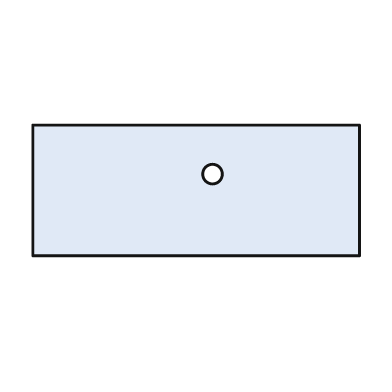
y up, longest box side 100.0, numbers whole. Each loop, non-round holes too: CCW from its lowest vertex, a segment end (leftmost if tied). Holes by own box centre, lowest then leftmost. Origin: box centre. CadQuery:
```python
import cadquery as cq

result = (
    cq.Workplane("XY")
    .moveTo(-50.0, -20.0)
    .lineTo(50.0, -20.0)
    .lineTo(50.0, 20.0)
    .lineTo(-50.0, 20.0)
    .close()
    .moveTo(5.0, 5.0)
    .circle(3.0)
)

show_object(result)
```